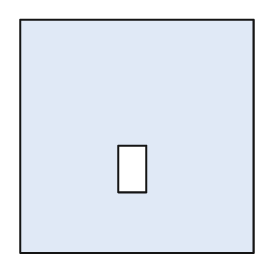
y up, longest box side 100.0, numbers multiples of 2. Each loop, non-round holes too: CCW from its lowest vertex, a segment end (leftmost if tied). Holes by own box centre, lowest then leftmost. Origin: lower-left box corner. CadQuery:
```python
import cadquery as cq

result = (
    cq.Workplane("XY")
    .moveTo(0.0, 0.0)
    .lineTo(100.0, 0.0)
    .lineTo(100.0, 100.0)
    .lineTo(0.0, 100.0)
    .close()
    .moveTo(42.0, 26.0)
    .lineTo(54.0, 26.0)
    .lineTo(54.0, 46.0)
    .lineTo(42.0, 46.0)
    .close()
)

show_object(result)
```